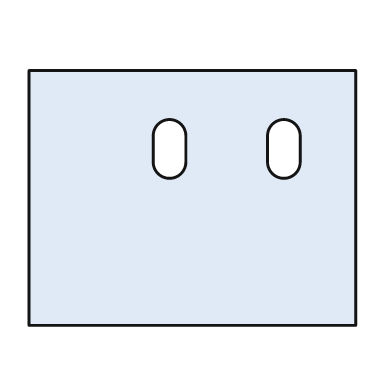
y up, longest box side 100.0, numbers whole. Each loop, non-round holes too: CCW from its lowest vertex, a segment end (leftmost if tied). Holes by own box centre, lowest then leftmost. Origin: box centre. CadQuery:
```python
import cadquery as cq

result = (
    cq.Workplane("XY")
    .moveTo(-50.0, -39.0)
    .lineTo(50.0, -39.0)
    .lineTo(50.0, 39.0)
    .lineTo(-50.0, 39.0)
    .close()
    .moveTo(-12.0, 11.0)
    .threePointArc((-7.0, 6.0), (-2.0, 11.0))
    .lineTo(-2.0, 19.0)
    .threePointArc((-7.0, 24.0), (-12.0, 19.0))
    .close()
    .moveTo(23.0, 11.0)
    .threePointArc((28.0, 6.0), (33.0, 11.0))
    .lineTo(33.0, 19.0)
    .threePointArc((28.0, 24.0), (23.0, 19.0))
    .close()
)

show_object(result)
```